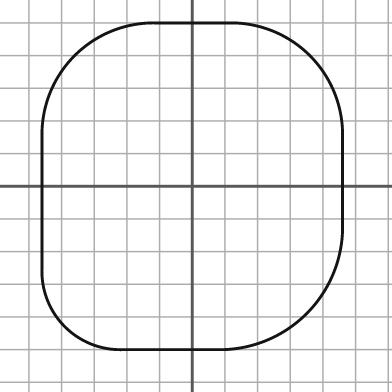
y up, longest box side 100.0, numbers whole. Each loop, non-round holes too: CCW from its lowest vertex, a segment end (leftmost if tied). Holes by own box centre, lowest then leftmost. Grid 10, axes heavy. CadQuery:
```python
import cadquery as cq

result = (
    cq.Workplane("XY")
    .moveTo(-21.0, -50.0)
    .lineTo(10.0, -50.0)
    .threePointArc((35.0, -39.0), (46.0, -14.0))
    .lineTo(46.0, 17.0)
    .threePointArc((36.0, 40.0), (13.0, 50.0))
    .lineTo(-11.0, 50.0)
    .threePointArc((-36.0, 40.0), (-46.0, 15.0))
    .lineTo(-46.0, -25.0)
    .threePointArc((-39.0, -43.0), (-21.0, -50.0))
    .close()
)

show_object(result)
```